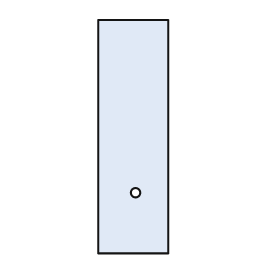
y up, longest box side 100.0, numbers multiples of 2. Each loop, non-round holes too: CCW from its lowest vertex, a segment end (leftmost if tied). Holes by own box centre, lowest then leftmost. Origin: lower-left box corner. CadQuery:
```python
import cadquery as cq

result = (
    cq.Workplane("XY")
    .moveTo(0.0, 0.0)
    .lineTo(30.0, 0.0)
    .lineTo(30.0, 100.0)
    .lineTo(0.0, 100.0)
    .close()
    .moveTo(16.0, 26.0)
    .circle(2.0)
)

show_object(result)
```